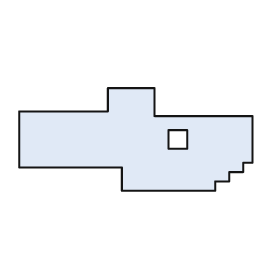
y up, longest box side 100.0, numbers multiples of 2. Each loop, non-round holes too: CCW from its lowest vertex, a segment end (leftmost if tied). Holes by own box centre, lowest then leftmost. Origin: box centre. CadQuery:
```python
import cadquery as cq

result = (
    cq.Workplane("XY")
    .moveTo(-6.0, -22.0)
    .lineTo(34.0, -22.0)
    .lineTo(34.0, -18.0)
    .lineTo(40.0, -18.0)
    .lineTo(40.0, -14.0)
    .lineTo(46.0, -14.0)
    .lineTo(46.0, -10.0)
    .lineTo(50.0, -10.0)
    .lineTo(50.0, 10.0)
    .lineTo(8.0, 10.0)
    .lineTo(8.0, 22.0)
    .lineTo(-12.0, 22.0)
    .lineTo(-12.0, 12.0)
    .lineTo(-50.0, 12.0)
    .lineTo(-50.0, -12.0)
    .lineTo(-6.0, -12.0)
    .close()
    .moveTo(14.0, -4.0)
    .lineTo(22.0, -4.0)
    .lineTo(22.0, 4.0)
    .lineTo(14.0, 4.0)
    .close()
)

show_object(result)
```